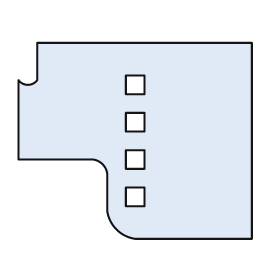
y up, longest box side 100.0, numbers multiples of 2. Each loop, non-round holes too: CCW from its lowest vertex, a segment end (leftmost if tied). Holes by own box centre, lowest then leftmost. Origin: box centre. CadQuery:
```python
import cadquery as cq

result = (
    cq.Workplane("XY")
    .moveTo(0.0, -42.0)
    .lineTo(50.0, -42.0)
    .lineTo(50.0, 42.0)
    .lineTo(-42.0, 42.0)
    .lineTo(-42.0, 26.0)
    .threePointArc((-46.0, 24.0), (-50.0, 26.0))
    .lineTo(-50.0, -8.0)
    .lineTo(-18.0, -8.0)
    .threePointArc((-14.0, -10.0), (-12.0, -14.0))
    .lineTo(-12.0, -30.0)
    .threePointArc((-8.0, -38.0), (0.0, -42.0))
    .close()
    .moveTo(-4.0, -28.0)
    .lineTo(4.0, -28.0)
    .lineTo(4.0, -20.0)
    .lineTo(-4.0, -20.0)
    .close()
    .moveTo(-4.0, -12.0)
    .lineTo(4.0, -12.0)
    .lineTo(4.0, -4.0)
    .lineTo(-4.0, -4.0)
    .close()
    .moveTo(-4.0, 4.0)
    .lineTo(4.0, 4.0)
    .lineTo(4.0, 12.0)
    .lineTo(-4.0, 12.0)
    .close()
    .moveTo(-4.0, 20.0)
    .lineTo(4.0, 20.0)
    .lineTo(4.0, 28.0)
    .lineTo(-4.0, 28.0)
    .close()
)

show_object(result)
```